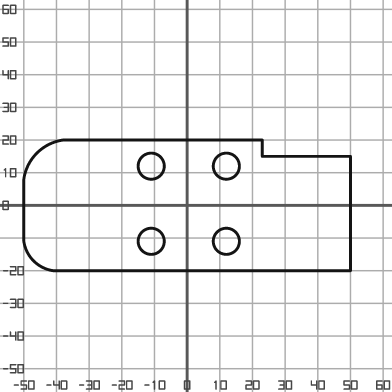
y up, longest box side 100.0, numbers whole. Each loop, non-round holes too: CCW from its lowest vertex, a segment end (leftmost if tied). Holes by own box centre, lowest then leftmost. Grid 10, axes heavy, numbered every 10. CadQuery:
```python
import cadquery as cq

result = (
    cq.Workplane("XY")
    .moveTo(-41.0, -20.0)
    .lineTo(50.0, -20.0)
    .lineTo(50.0, 15.0)
    .lineTo(23.0, 15.0)
    .lineTo(23.0, 20.0)
    .lineTo(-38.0, 20.0)
    .threePointArc((-46.0, 16.0), (-50.0, 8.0))
    .lineTo(-50.0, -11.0)
    .threePointArc((-47.0, -17.0), (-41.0, -20.0))
    .close()
    .moveTo(-11.0, -11.0)
    .circle(4.0)
    .moveTo(12.0, -11.0)
    .circle(4.0)
    .moveTo(-11.0, 12.0)
    .circle(4.0)
    .moveTo(12.0, 12.0)
    .circle(4.0)
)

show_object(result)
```